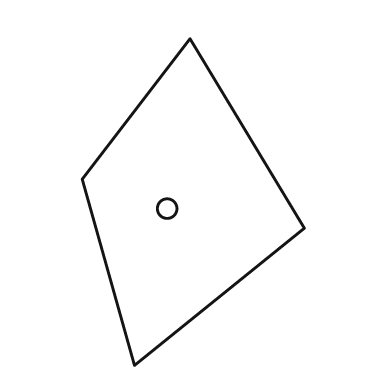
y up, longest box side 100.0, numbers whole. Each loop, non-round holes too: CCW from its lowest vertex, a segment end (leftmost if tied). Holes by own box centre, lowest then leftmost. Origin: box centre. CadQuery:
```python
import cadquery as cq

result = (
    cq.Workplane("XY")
    .moveTo(-18.0, -50.0)
    .lineTo(34.0, -8.0)
    .lineTo(-1.0, 50.0)
    .lineTo(-34.0, 7.0)
    .close()
    .moveTo(-8.0, -2.0)
    .circle(3.0)
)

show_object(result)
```